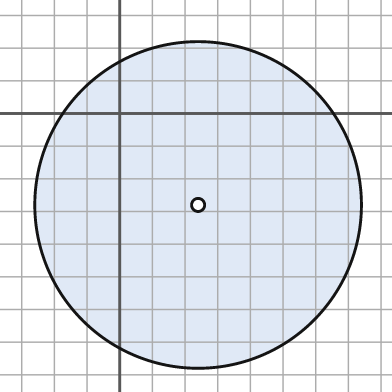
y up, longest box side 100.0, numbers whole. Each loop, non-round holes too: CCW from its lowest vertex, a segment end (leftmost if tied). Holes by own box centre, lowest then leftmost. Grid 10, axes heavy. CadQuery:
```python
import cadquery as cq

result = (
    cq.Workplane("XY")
    .moveTo(24.0, -28.0)
    .circle(50.0)
    .moveTo(24.0, -28.0)
    .circle(2.0)
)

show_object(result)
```